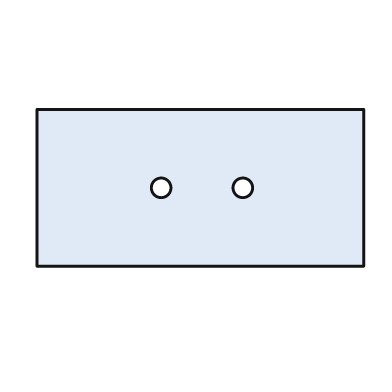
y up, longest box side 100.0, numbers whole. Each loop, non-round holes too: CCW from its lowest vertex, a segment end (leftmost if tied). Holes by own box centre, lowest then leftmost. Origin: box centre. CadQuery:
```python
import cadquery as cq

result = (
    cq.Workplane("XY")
    .moveTo(-50.0, -24.0)
    .lineTo(50.0, -24.0)
    .lineTo(50.0, 24.0)
    .lineTo(-50.0, 24.0)
    .close()
    .moveTo(-12.0, 0.0)
    .circle(3.0)
    .moveTo(13.0, 0.0)
    .circle(3.0)
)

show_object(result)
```